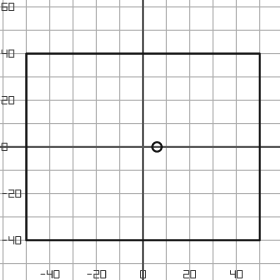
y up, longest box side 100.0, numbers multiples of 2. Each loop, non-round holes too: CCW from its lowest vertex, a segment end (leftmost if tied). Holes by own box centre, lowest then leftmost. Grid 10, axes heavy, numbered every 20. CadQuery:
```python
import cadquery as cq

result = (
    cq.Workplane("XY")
    .moveTo(-50.0, -40.0)
    .lineTo(50.0, -40.0)
    .lineTo(50.0, 40.0)
    .lineTo(-50.0, 40.0)
    .close()
    .moveTo(6.0, 0.0)
    .circle(2.0)
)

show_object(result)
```